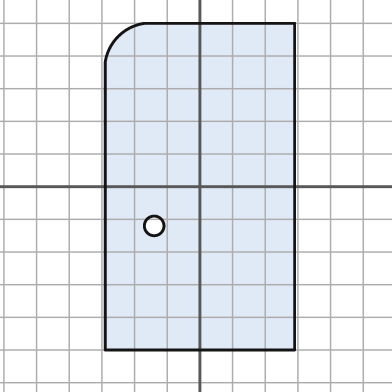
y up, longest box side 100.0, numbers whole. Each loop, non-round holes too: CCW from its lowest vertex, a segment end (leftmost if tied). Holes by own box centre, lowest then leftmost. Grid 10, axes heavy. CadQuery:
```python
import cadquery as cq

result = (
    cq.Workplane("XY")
    .moveTo(-29.0, -50.0)
    .lineTo(29.0, -50.0)
    .lineTo(29.0, 50.0)
    .lineTo(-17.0, 50.0)
    .threePointArc((-25.0, 46.0), (-29.0, 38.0))
    .close()
    .moveTo(-14.0, -12.0)
    .circle(3.0)
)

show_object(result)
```